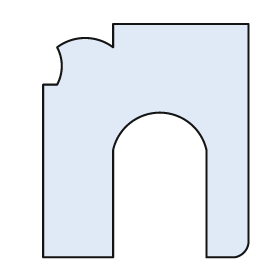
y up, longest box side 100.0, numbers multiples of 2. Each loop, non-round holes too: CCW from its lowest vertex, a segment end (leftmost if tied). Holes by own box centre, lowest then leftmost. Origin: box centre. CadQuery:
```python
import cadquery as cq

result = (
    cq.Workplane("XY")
    .moveTo(-44.0, -50.0)
    .lineTo(-14.0, -50.0)
    .lineTo(-14.0, -4.0)
    .threePointArc((6.0, 12.0), (26.0, -4.0))
    .lineTo(26.0, -50.0)
    .lineTo(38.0, -50.0)
    .threePointArc((42.0, -48.0), (44.0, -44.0))
    .lineTo(44.0, 50.0)
    .lineTo(-14.0, 50.0)
    .lineTo(-14.0, 40.0)
    .threePointArc((-26.0, 44.0), (-38.0, 40.0))
    .threePointArc((-36.0, 32.0), (-38.0, 24.0))
    .lineTo(-44.0, 24.0)
    .close()
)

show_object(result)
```